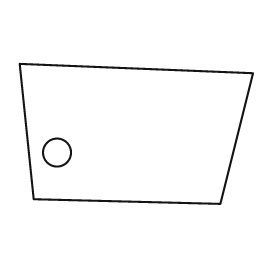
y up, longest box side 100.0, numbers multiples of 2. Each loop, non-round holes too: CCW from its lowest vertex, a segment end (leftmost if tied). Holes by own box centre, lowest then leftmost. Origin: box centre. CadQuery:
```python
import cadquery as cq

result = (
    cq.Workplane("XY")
    .moveTo(36.0, -30.0)
    .lineTo(50.0, 26.0)
    .lineTo(-50.0, 30.0)
    .lineTo(-44.0, -28.0)
    .close()
    .moveTo(-34.0, -8.0)
    .circle(6.0)
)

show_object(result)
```